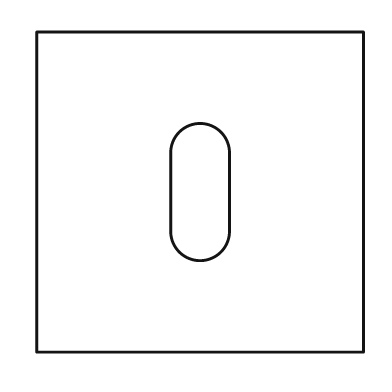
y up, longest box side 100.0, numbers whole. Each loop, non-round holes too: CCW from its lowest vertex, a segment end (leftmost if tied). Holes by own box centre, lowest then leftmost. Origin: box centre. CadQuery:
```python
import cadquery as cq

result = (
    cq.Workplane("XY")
    .moveTo(-50.0, -49.0)
    .lineTo(50.0, -49.0)
    .lineTo(50.0, 49.0)
    .lineTo(-50.0, 49.0)
    .close()
    .moveTo(-9.0, -12.0)
    .threePointArc((0.0, -21.0), (9.0, -12.0))
    .lineTo(9.0, 12.0)
    .threePointArc((0.0, 21.0), (-9.0, 12.0))
    .close()
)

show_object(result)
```